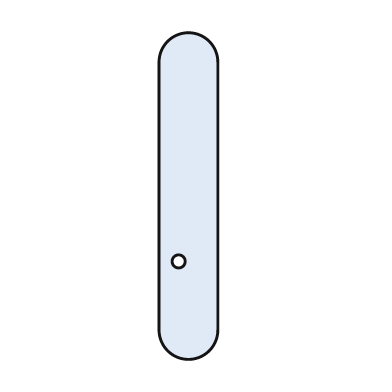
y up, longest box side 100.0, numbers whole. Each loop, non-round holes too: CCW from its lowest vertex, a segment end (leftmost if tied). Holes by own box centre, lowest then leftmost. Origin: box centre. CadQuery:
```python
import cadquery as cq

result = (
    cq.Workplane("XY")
    .moveTo(-9.0, -41.0)
    .threePointArc((0.0, -50.0), (9.0, -41.0))
    .lineTo(9.0, 41.0)
    .threePointArc((0.0, 50.0), (-9.0, 41.0))
    .close()
    .moveTo(-3.0, -20.0)
    .circle(2.0)
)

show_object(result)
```